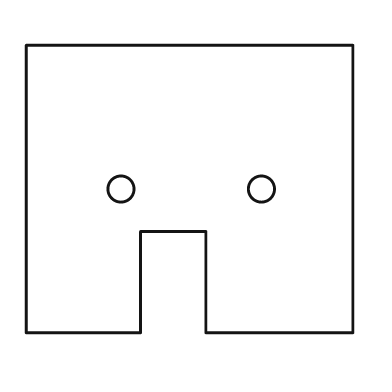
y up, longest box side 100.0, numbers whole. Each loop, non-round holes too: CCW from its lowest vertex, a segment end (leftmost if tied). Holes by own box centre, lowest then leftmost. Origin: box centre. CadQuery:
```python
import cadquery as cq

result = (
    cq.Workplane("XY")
    .moveTo(-50.0, -44.0)
    .lineTo(-15.0, -44.0)
    .lineTo(-15.0, -13.0)
    .lineTo(5.0, -13.0)
    .lineTo(5.0, -44.0)
    .lineTo(50.0, -44.0)
    .lineTo(50.0, 44.0)
    .lineTo(-50.0, 44.0)
    .close()
    .moveTo(-21.0, 0.0)
    .circle(4.0)
    .moveTo(22.0, 0.0)
    .circle(4.0)
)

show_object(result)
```